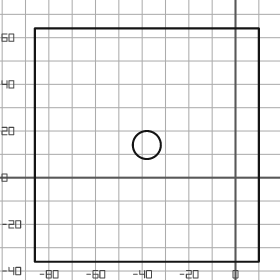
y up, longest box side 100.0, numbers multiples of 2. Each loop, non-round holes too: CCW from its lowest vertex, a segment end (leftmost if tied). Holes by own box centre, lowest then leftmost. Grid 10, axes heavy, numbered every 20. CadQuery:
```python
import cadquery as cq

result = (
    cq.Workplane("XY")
    .moveTo(-86.0, -36.0)
    .lineTo(10.0, -36.0)
    .lineTo(10.0, 64.0)
    .lineTo(-86.0, 64.0)
    .close()
    .moveTo(-38.0, 14.0)
    .circle(6.0)
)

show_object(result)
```